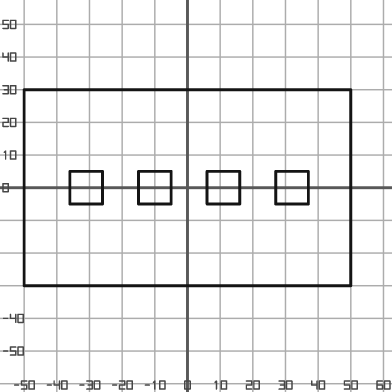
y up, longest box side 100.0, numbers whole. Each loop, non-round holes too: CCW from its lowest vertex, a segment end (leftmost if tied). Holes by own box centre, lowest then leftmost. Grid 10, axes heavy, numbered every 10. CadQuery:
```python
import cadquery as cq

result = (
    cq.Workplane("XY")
    .moveTo(-50.0, -30.0)
    .lineTo(50.0, -30.0)
    .lineTo(50.0, 30.0)
    .lineTo(-50.0, 30.0)
    .close()
    .moveTo(-36.0, -5.0)
    .lineTo(-26.0, -5.0)
    .lineTo(-26.0, 5.0)
    .lineTo(-36.0, 5.0)
    .close()
    .moveTo(-15.0, -5.0)
    .lineTo(-5.0, -5.0)
    .lineTo(-5.0, 5.0)
    .lineTo(-15.0, 5.0)
    .close()
    .moveTo(6.0, -5.0)
    .lineTo(16.0, -5.0)
    .lineTo(16.0, 5.0)
    .lineTo(6.0, 5.0)
    .close()
    .moveTo(27.0, -5.0)
    .lineTo(37.0, -5.0)
    .lineTo(37.0, 5.0)
    .lineTo(27.0, 5.0)
    .close()
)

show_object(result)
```